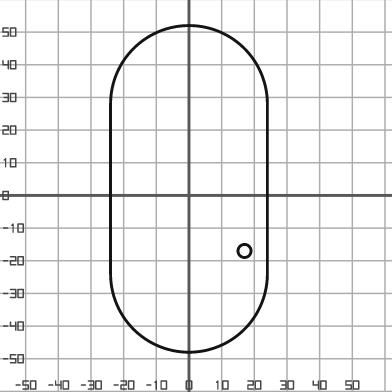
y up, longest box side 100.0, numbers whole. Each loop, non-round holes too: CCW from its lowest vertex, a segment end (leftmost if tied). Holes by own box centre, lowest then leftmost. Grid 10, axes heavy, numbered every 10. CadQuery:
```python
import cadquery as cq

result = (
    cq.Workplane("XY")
    .moveTo(-24.0, -24.0)
    .threePointArc((0.0, -48.0), (24.0, -24.0))
    .lineTo(24.0, 28.0)
    .threePointArc((0.0, 52.0), (-24.0, 28.0))
    .close()
    .moveTo(17.0, -17.0)
    .circle(2.0)
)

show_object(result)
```